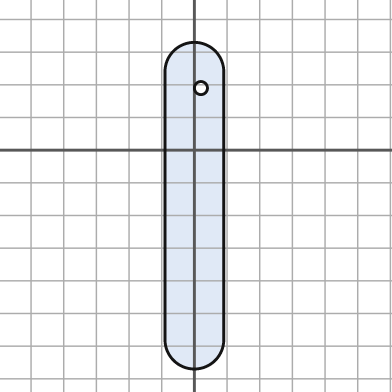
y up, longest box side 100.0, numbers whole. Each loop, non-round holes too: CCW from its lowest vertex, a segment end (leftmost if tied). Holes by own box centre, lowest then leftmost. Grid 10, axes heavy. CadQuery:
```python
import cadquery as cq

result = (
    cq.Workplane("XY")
    .moveTo(-9.0, -58.0)
    .threePointArc((0.0, -67.0), (9.0, -58.0))
    .lineTo(9.0, 24.0)
    .threePointArc((0.0, 33.0), (-9.0, 24.0))
    .close()
    .moveTo(2.0, 19.0)
    .circle(2.0)
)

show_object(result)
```